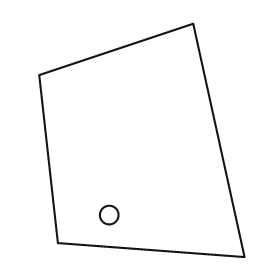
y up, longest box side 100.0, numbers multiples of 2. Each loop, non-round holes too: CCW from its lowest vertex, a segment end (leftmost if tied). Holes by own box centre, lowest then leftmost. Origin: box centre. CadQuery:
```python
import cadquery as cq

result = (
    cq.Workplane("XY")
    .moveTo(44.0, -50.0)
    .lineTo(22.0, 50.0)
    .lineTo(-44.0, 28.0)
    .lineTo(-36.0, -44.0)
    .close()
    .moveTo(-14.0, -32.0)
    .circle(4.0)
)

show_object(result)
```